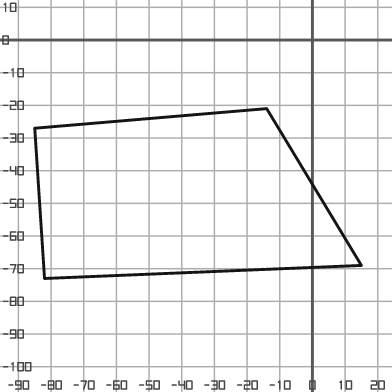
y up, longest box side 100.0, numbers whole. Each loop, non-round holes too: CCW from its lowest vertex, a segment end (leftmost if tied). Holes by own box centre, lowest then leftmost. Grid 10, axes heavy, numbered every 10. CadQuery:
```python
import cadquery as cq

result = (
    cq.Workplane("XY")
    .moveTo(-82.0, -73.0)
    .lineTo(15.0, -69.0)
    .lineTo(-14.0, -21.0)
    .lineTo(-85.0, -27.0)
    .close()
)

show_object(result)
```